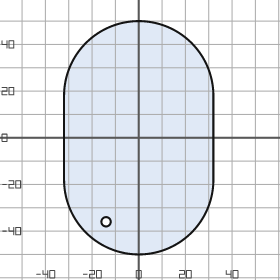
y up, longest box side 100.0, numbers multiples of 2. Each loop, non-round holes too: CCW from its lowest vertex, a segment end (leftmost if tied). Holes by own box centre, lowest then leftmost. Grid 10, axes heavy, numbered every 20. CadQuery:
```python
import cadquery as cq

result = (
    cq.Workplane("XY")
    .moveTo(-32.0, -18.0)
    .threePointArc((0.0, -50.0), (32.0, -18.0))
    .lineTo(32.0, 18.0)
    .threePointArc((0.0, 50.0), (-32.0, 18.0))
    .close()
    .moveTo(-14.0, -36.0)
    .circle(2.0)
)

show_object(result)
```